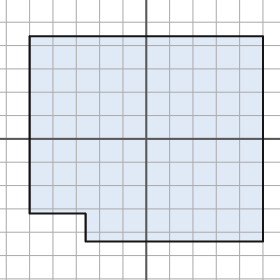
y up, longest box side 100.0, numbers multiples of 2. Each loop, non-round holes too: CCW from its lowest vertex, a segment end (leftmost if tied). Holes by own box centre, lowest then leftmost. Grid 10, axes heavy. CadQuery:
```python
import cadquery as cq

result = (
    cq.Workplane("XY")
    .moveTo(-26.0, -44.0)
    .lineTo(50.0, -44.0)
    .lineTo(50.0, 44.0)
    .lineTo(-50.0, 44.0)
    .lineTo(-50.0, -32.0)
    .lineTo(-26.0, -32.0)
    .close()
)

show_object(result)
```